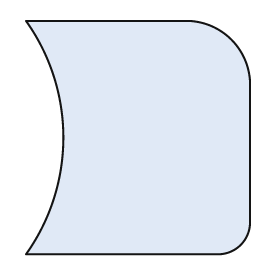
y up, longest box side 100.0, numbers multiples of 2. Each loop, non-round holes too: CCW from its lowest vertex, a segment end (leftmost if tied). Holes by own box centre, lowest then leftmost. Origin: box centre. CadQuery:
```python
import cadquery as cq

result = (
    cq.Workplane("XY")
    .moveTo(-48.0, -50.0)
    .lineTo(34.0, -50.0)
    .threePointArc((44.0, -46.0), (48.0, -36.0))
    .lineTo(48.0, 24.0)
    .threePointArc((40.0, 42.0), (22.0, 50.0))
    .lineTo(-48.0, 50.0)
    .threePointArc((-32.0, 0.0), (-48.0, -50.0))
    .close()
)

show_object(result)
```